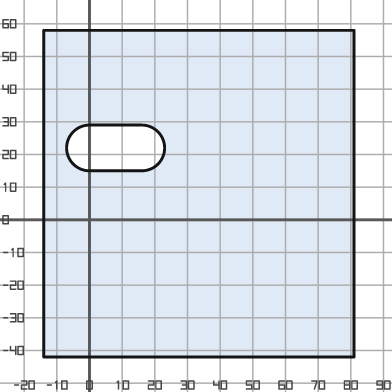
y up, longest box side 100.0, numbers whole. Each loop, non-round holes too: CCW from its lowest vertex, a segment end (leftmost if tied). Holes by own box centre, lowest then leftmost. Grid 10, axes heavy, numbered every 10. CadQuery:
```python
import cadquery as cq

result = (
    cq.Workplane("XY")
    .moveTo(-14.0, -42.0)
    .lineTo(81.0, -42.0)
    .lineTo(81.0, 58.0)
    .lineTo(-14.0, 58.0)
    .close()
    .moveTo(0.0, 15.0)
    .lineTo(16.0, 15.0)
    .threePointArc((23.0, 22.0), (16.0, 29.0))
    .lineTo(0.0, 29.0)
    .threePointArc((-7.0, 22.0), (0.0, 15.0))
    .close()
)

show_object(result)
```